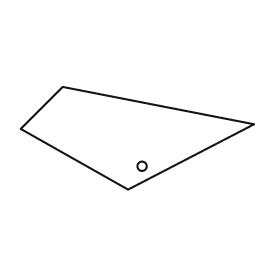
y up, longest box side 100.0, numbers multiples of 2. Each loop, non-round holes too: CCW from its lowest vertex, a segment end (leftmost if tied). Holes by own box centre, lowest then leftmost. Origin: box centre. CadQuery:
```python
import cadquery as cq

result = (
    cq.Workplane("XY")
    .moveTo(-4.0, -22.0)
    .lineTo(50.0, 6.0)
    .lineTo(-32.0, 22.0)
    .lineTo(-50.0, 4.0)
    .close()
    .moveTo(2.0, -12.0)
    .circle(2.0)
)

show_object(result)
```